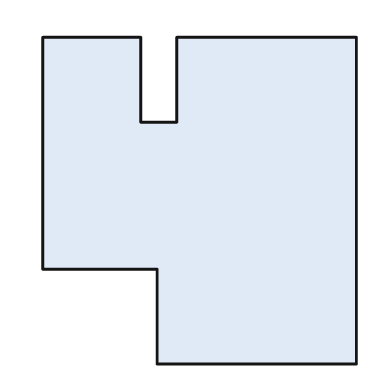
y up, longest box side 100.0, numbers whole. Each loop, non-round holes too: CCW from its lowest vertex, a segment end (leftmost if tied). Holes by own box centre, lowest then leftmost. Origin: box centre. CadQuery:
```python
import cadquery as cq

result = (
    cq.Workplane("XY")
    .moveTo(-13.0, -50.0)
    .lineTo(48.0, -50.0)
    .lineTo(48.0, 50.0)
    .lineTo(-7.0, 50.0)
    .lineTo(-7.0, 24.0)
    .lineTo(-18.0, 24.0)
    .lineTo(-18.0, 50.0)
    .lineTo(-48.0, 50.0)
    .lineTo(-48.0, -21.0)
    .lineTo(-13.0, -21.0)
    .close()
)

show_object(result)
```